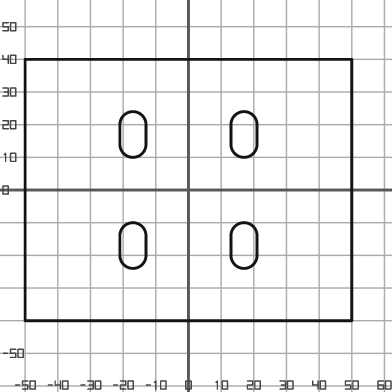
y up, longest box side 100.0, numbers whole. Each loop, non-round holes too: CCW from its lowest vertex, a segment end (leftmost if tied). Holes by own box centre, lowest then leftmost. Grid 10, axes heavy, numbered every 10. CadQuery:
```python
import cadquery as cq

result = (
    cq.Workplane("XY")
    .moveTo(-50.0, -40.0)
    .lineTo(50.0, -40.0)
    .lineTo(50.0, 40.0)
    .lineTo(-50.0, 40.0)
    .close()
    .moveTo(-21.0, -20.0)
    .threePointArc((-17.0, -24.0), (-13.0, -20.0))
    .lineTo(-13.0, -14.0)
    .threePointArc((-17.0, -10.0), (-21.0, -14.0))
    .close()
    .moveTo(13.0, -20.0)
    .threePointArc((17.0, -24.0), (21.0, -20.0))
    .lineTo(21.0, -14.0)
    .threePointArc((17.0, -10.0), (13.0, -14.0))
    .close()
    .moveTo(-21.0, 14.0)
    .threePointArc((-17.0, 10.0), (-13.0, 14.0))
    .lineTo(-13.0, 20.0)
    .threePointArc((-17.0, 24.0), (-21.0, 20.0))
    .close()
    .moveTo(13.0, 14.0)
    .threePointArc((17.0, 10.0), (21.0, 14.0))
    .lineTo(21.0, 20.0)
    .threePointArc((17.0, 24.0), (13.0, 20.0))
    .close()
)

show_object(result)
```